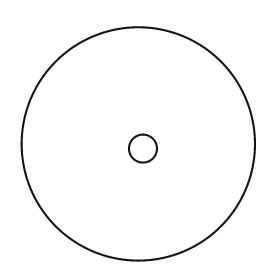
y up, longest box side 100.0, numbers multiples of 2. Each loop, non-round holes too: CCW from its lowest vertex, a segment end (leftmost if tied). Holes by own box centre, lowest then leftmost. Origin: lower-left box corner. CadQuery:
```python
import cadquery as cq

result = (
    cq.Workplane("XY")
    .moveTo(50.0, 50.0)
    .circle(50.0)
    .moveTo(52.0, 48.0)
    .circle(6.0)
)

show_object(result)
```